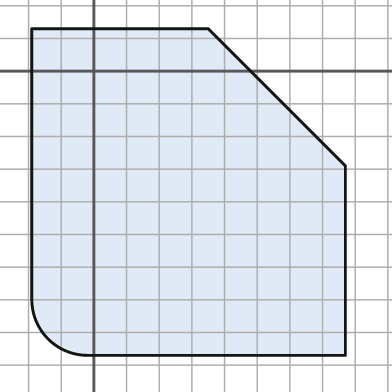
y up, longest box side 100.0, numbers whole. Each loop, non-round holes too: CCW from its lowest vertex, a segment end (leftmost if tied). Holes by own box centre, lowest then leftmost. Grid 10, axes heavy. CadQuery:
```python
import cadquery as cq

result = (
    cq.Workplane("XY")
    .moveTo(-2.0, -87.0)
    .lineTo(77.0, -87.0)
    .lineTo(77.0, -29.0)
    .lineTo(35.0, 13.0)
    .lineTo(-19.0, 13.0)
    .lineTo(-19.0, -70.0)
    .threePointArc((-14.0, -82.0), (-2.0, -87.0))
    .close()
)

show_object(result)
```